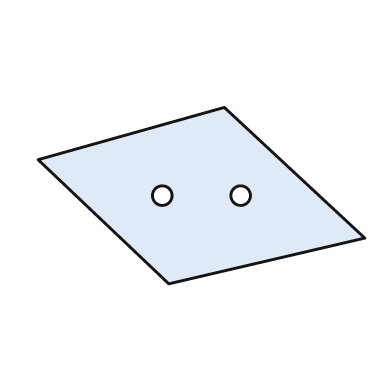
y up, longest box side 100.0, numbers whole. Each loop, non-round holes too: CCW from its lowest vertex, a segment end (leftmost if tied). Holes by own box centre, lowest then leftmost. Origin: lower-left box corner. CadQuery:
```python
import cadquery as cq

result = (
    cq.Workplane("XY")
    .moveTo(40.0, 0.0)
    .lineTo(100.0, 14.0)
    .lineTo(57.0, 54.0)
    .lineTo(0.0, 38.0)
    .close()
    .moveTo(38.0, 27.0)
    .circle(3.0)
    .moveTo(62.0, 27.0)
    .circle(3.0)
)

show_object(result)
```